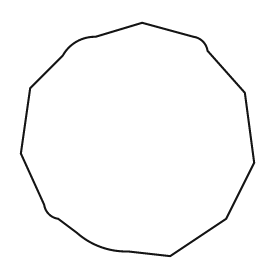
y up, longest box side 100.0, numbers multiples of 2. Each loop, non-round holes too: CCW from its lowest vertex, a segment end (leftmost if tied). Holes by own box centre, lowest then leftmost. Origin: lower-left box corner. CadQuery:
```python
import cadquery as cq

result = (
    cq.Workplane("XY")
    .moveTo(64.0, 0.0)
    .lineTo(88.0, 16.0)
    .lineTo(100.0, 40.0)
    .lineTo(96.0, 70.0)
    .lineTo(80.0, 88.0)
    .threePointArc((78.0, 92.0), (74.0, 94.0))
    .lineTo(52.0, 100.0)
    .lineTo(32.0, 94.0)
    .threePointArc((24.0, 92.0), (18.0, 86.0))
    .lineTo(4.0, 72.0)
    .lineTo(0.0, 44.0)
    .lineTo(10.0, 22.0)
    .threePointArc((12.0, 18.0), (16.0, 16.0))
    .lineTo(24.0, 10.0)
    .threePointArc((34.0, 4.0), (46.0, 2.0))
    .close()
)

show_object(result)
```